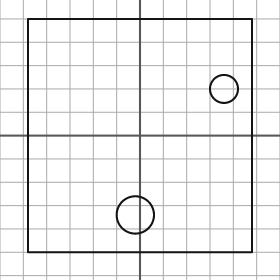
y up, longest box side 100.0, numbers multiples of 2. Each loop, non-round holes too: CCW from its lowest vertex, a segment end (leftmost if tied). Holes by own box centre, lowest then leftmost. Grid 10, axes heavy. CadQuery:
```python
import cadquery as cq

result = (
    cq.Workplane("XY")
    .moveTo(-48.0, -50.0)
    .lineTo(48.0, -50.0)
    .lineTo(48.0, 50.0)
    .lineTo(-48.0, 50.0)
    .close()
    .moveTo(-2.0, -34.0)
    .circle(8.0)
    .moveTo(36.0, 20.0)
    .circle(6.0)
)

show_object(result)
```